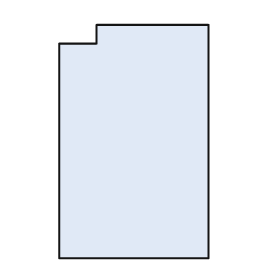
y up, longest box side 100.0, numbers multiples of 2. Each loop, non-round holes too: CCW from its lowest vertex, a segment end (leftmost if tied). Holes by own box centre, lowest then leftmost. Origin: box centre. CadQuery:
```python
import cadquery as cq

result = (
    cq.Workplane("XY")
    .moveTo(-32.0, -50.0)
    .lineTo(32.0, -50.0)
    .lineTo(32.0, 50.0)
    .lineTo(-16.0, 50.0)
    .lineTo(-16.0, 42.0)
    .lineTo(-32.0, 42.0)
    .close()
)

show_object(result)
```